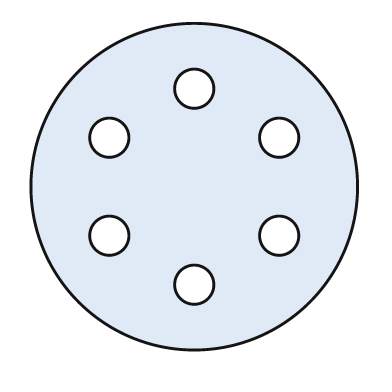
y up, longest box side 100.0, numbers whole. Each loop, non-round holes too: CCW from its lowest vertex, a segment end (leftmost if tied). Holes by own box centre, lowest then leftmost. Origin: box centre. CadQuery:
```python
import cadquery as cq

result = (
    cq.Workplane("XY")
    .moveTo(0.0, 0.0)
    .circle(50.0)
    .moveTo(0.0, -30.0)
    .circle(6.0)
    .moveTo(-26.0, -15.0)
    .circle(6.0)
    .moveTo(26.0, -15.0)
    .circle(6.0)
    .moveTo(-26.0, 15.0)
    .circle(6.0)
    .moveTo(26.0, 15.0)
    .circle(6.0)
    .moveTo(0.0, 30.0)
    .circle(6.0)
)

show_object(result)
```